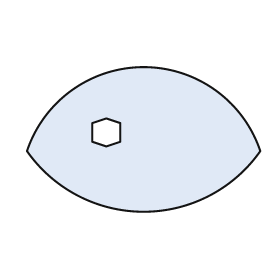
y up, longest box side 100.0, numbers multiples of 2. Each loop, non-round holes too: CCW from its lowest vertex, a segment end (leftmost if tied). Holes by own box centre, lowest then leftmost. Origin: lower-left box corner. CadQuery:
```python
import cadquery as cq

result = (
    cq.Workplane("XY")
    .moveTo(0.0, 26.0)
    .threePointArc((50.0, 0.0), (100.0, 26.0))
    .threePointArc((50.0, 62.0), (0.0, 26.0))
    .close()
    .moveTo(34.0, 28.0)
    .lineTo(40.0, 30.0)
    .lineTo(40.0, 38.0)
    .lineTo(34.0, 40.0)
    .lineTo(28.0, 38.0)
    .lineTo(28.0, 30.0)
    .close()
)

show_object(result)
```